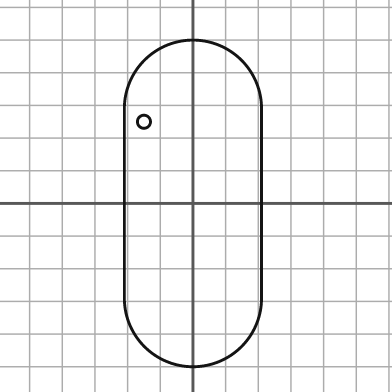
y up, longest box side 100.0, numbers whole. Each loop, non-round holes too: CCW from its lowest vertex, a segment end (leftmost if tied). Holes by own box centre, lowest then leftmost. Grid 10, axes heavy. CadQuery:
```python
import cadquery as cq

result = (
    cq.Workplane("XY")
    .moveTo(-21.0, -29.0)
    .threePointArc((0.0, -50.0), (21.0, -29.0))
    .lineTo(21.0, 29.0)
    .threePointArc((0.0, 50.0), (-21.0, 29.0))
    .close()
    .moveTo(-15.0, 25.0)
    .circle(2.0)
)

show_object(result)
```